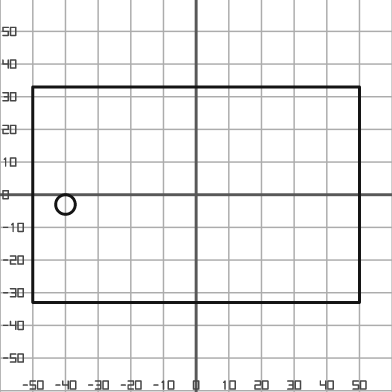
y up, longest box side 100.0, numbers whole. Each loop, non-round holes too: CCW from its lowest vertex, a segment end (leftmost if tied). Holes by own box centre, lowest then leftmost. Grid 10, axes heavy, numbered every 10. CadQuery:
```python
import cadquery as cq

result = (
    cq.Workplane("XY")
    .moveTo(-50.0, -33.0)
    .lineTo(50.0, -33.0)
    .lineTo(50.0, 33.0)
    .lineTo(-50.0, 33.0)
    .close()
    .moveTo(-40.0, -3.0)
    .circle(3.0)
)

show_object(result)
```